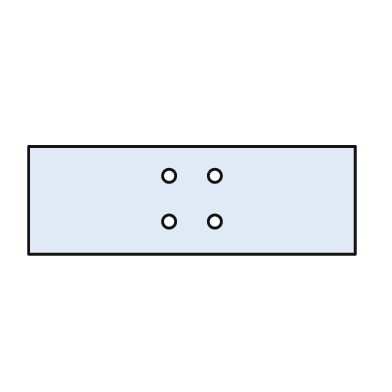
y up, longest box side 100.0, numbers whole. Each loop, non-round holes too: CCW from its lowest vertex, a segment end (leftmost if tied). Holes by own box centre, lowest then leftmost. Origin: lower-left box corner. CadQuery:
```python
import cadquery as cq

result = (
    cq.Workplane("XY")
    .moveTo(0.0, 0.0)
    .lineTo(100.0, 0.0)
    .lineTo(100.0, 33.0)
    .lineTo(0.0, 33.0)
    .close()
    .moveTo(43.0, 10.0)
    .circle(2.0)
    .moveTo(57.0, 10.0)
    .circle(2.0)
    .moveTo(43.0, 24.0)
    .circle(2.0)
    .moveTo(57.0, 24.0)
    .circle(2.0)
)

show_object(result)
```